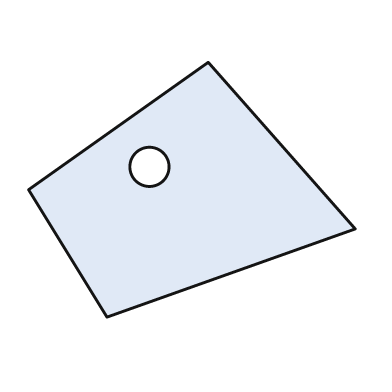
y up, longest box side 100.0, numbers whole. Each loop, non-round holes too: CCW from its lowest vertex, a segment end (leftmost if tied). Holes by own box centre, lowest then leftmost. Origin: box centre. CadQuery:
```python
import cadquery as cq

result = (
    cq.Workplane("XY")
    .moveTo(-26.0, -39.0)
    .lineTo(50.0, -12.0)
    .lineTo(5.0, 39.0)
    .lineTo(-50.0, 0.0)
    .close()
    .moveTo(-13.0, 7.0)
    .circle(6.0)
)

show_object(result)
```